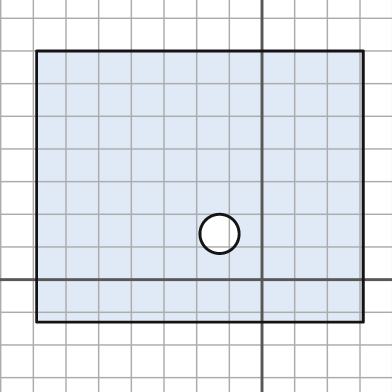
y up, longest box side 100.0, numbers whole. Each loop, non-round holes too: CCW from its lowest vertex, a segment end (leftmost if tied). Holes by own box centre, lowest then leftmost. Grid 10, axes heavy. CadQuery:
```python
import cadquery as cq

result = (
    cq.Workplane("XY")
    .moveTo(-69.0, -13.0)
    .lineTo(31.0, -13.0)
    .lineTo(31.0, 70.0)
    .lineTo(-69.0, 70.0)
    .close()
    .moveTo(-13.0, 14.0)
    .circle(6.0)
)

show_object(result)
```